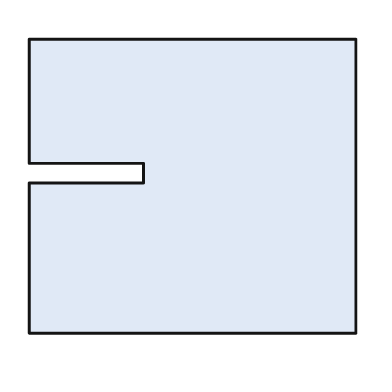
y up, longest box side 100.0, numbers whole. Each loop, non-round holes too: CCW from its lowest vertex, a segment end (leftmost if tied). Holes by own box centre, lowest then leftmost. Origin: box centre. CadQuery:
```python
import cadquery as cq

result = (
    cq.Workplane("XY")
    .moveTo(-50.0, -45.0)
    .lineTo(50.0, -45.0)
    .lineTo(50.0, 45.0)
    .lineTo(-50.0, 45.0)
    .lineTo(-50.0, 7.0)
    .lineTo(-15.0, 7.0)
    .lineTo(-15.0, 1.0)
    .lineTo(-50.0, 1.0)
    .close()
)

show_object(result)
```